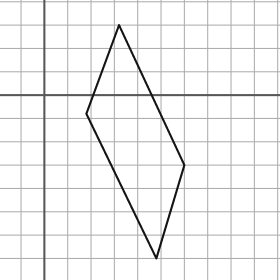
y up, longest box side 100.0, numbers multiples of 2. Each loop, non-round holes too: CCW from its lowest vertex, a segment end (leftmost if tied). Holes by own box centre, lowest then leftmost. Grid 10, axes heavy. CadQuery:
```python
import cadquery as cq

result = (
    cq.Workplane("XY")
    .moveTo(48.0, -70.0)
    .lineTo(60.0, -30.0)
    .lineTo(32.0, 30.0)
    .lineTo(18.0, -8.0)
    .close()
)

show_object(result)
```